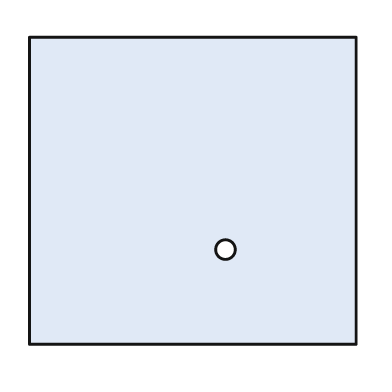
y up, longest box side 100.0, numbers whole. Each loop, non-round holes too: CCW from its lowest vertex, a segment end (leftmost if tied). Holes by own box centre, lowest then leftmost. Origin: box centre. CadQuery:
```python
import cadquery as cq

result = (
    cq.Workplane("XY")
    .moveTo(-50.0, -47.0)
    .lineTo(50.0, -47.0)
    .lineTo(50.0, 47.0)
    .lineTo(-50.0, 47.0)
    .close()
    .moveTo(10.0, -18.0)
    .circle(3.0)
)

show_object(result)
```